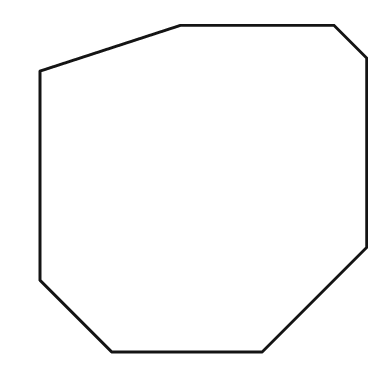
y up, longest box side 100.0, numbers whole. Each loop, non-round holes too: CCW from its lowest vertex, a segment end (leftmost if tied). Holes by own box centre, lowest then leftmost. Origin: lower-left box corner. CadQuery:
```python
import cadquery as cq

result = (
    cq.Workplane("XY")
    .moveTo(22.0, 0.0)
    .lineTo(68.0, 0.0)
    .lineTo(100.0, 32.0)
    .lineTo(100.0, 90.0)
    .lineTo(90.0, 100.0)
    .lineTo(43.0, 100.0)
    .lineTo(0.0, 86.0)
    .lineTo(0.0, 22.0)
    .close()
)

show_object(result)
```